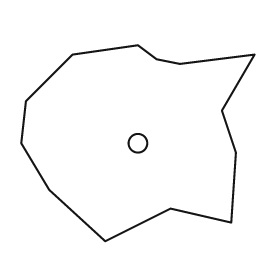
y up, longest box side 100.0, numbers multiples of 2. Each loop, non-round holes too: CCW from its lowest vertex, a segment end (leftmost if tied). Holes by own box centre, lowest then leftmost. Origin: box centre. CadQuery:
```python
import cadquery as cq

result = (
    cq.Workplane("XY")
    .moveTo(-14.0, -42.0)
    .lineTo(14.0, -28.0)
    .lineTo(40.0, -34.0)
    .lineTo(42.0, -4.0)
    .lineTo(36.0, 14.0)
    .lineTo(50.0, 38.0)
    .lineTo(18.0, 34.0)
    .lineTo(8.0, 36.0)
    .lineTo(0.0, 42.0)
    .lineTo(-28.0, 38.0)
    .lineTo(-48.0, 18.0)
    .lineTo(-50.0, 0.0)
    .lineTo(-38.0, -20.0)
    .close()
    .moveTo(0.0, 0.0)
    .circle(4.0)
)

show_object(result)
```